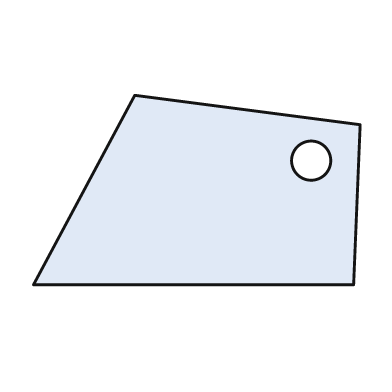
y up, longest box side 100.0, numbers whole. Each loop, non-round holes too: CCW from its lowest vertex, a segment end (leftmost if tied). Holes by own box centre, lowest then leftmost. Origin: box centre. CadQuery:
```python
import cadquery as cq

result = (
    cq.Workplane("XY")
    .moveTo(-50.0, -29.0)
    .lineTo(48.0, -29.0)
    .lineTo(50.0, 20.0)
    .lineTo(-19.0, 29.0)
    .close()
    .moveTo(35.0, 9.0)
    .circle(6.0)
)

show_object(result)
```